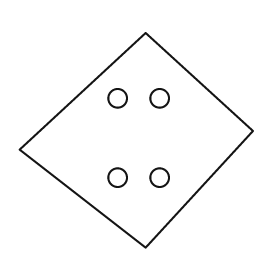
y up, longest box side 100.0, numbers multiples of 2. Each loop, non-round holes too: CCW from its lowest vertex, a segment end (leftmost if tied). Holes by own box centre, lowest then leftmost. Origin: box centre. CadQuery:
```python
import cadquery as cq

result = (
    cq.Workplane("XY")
    .moveTo(4.0, -46.0)
    .lineTo(50.0, 4.0)
    .lineTo(4.0, 46.0)
    .lineTo(-50.0, -4.0)
    .close()
    .moveTo(-8.0, -16.0)
    .circle(4.0)
    .moveTo(10.0, -16.0)
    .circle(4.0)
    .moveTo(-8.0, 18.0)
    .circle(4.0)
    .moveTo(10.0, 18.0)
    .circle(4.0)
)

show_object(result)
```